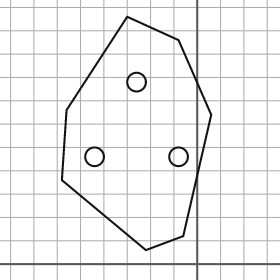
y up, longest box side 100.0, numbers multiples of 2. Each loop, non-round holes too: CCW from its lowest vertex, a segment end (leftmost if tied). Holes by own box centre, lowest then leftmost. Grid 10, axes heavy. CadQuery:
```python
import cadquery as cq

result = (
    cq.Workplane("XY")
    .moveTo(-22.0, 6.0)
    .lineTo(-6.0, 12.0)
    .lineTo(6.0, 64.0)
    .lineTo(-8.0, 96.0)
    .lineTo(-30.0, 106.0)
    .lineTo(-56.0, 66.0)
    .lineTo(-58.0, 36.0)
    .close()
    .moveTo(-44.0, 46.0)
    .circle(4.0)
    .moveTo(-8.0, 46.0)
    .circle(4.0)
    .moveTo(-26.0, 78.0)
    .circle(4.0)
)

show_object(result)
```